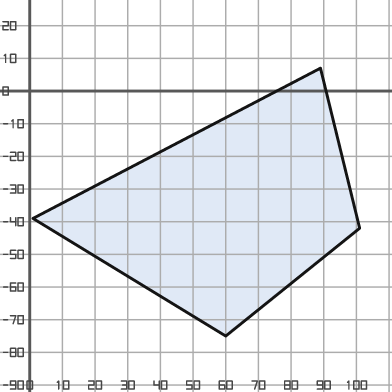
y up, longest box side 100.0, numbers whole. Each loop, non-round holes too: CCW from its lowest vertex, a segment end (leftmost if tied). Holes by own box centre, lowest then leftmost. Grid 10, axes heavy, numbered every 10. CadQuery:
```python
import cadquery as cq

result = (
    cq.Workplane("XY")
    .moveTo(60.0, -75.0)
    .lineTo(101.0, -42.0)
    .lineTo(89.0, 7.0)
    .lineTo(1.0, -39.0)
    .close()
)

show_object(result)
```